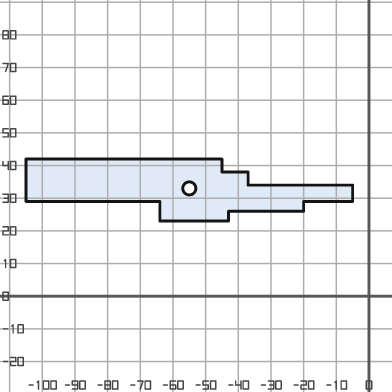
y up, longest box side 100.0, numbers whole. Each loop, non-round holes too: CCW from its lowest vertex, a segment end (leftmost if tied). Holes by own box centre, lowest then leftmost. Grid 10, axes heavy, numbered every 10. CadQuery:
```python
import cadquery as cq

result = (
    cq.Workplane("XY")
    .moveTo(-64.0, 23.0)
    .lineTo(-43.0, 23.0)
    .lineTo(-43.0, 26.0)
    .lineTo(-20.0, 26.0)
    .lineTo(-20.0, 29.0)
    .lineTo(-5.0, 29.0)
    .lineTo(-5.0, 34.0)
    .lineTo(-37.0, 34.0)
    .lineTo(-37.0, 38.0)
    .lineTo(-45.0, 38.0)
    .lineTo(-45.0, 42.0)
    .lineTo(-105.0, 42.0)
    .lineTo(-105.0, 29.0)
    .lineTo(-64.0, 29.0)
    .close()
    .moveTo(-55.0, 33.0)
    .circle(2.0)
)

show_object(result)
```